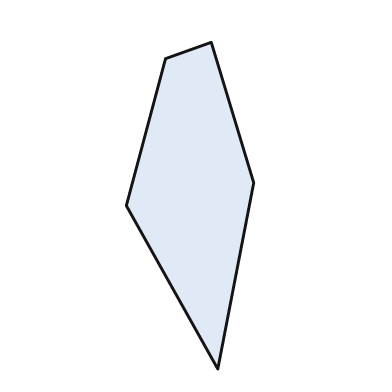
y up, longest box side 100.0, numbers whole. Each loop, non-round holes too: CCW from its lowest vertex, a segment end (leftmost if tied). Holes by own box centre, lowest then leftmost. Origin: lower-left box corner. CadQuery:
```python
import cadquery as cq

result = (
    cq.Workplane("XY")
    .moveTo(28.0, 0.0)
    .lineTo(39.0, 57.0)
    .lineTo(26.0, 100.0)
    .lineTo(12.0, 95.0)
    .lineTo(0.0, 50.0)
    .close()
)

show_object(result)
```